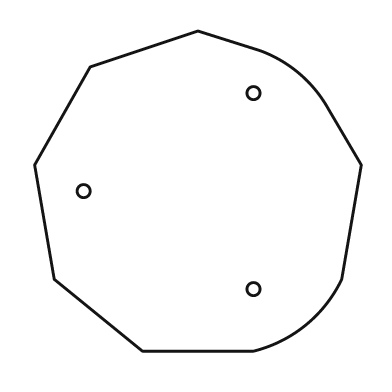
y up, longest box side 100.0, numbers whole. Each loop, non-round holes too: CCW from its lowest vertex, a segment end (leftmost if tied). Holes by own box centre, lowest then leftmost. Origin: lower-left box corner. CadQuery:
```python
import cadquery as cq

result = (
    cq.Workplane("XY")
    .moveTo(33.0, 0.0)
    .lineTo(67.0, 0.0)
    .threePointArc((83.0, 8.0), (94.0, 22.0))
    .lineTo(100.0, 57.0)
    .lineTo(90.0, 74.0)
    .threePointArc((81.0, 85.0), (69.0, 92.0))
    .lineTo(50.0, 98.0)
    .lineTo(17.0, 87.0)
    .lineTo(0.0, 57.0)
    .lineTo(6.0, 22.0)
    .close()
    .moveTo(67.0, 19.0)
    .circle(2.0)
    .moveTo(15.0, 49.0)
    .circle(2.0)
    .moveTo(67.0, 79.0)
    .circle(2.0)
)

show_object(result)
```